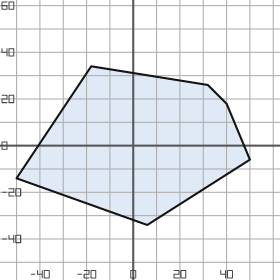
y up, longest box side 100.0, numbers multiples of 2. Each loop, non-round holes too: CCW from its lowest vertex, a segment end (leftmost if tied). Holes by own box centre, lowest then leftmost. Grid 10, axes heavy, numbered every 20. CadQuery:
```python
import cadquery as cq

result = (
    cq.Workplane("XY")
    .moveTo(6.0, -34.0)
    .lineTo(50.0, -6.0)
    .lineTo(40.0, 18.0)
    .lineTo(32.0, 26.0)
    .lineTo(-18.0, 34.0)
    .lineTo(-50.0, -14.0)
    .close()
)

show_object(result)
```